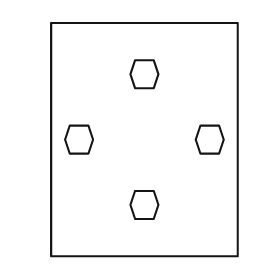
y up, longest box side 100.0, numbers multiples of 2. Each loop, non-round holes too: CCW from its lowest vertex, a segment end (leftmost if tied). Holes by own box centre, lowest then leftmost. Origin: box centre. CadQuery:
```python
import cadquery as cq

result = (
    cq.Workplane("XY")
    .moveTo(-40.0, -50.0)
    .lineTo(40.0, -50.0)
    .lineTo(40.0, 50.0)
    .lineTo(-40.0, 50.0)
    .close()
    .moveTo(-4.0, -34.0)
    .lineTo(4.0, -34.0)
    .lineTo(6.0, -28.0)
    .lineTo(4.0, -22.0)
    .lineTo(-4.0, -22.0)
    .lineTo(-6.0, -28.0)
    .close()
    .moveTo(-32.0, -6.0)
    .lineTo(-24.0, -6.0)
    .lineTo(-22.0, 0.0)
    .lineTo(-24.0, 6.0)
    .lineTo(-32.0, 6.0)
    .lineTo(-34.0, 0.0)
    .close()
    .moveTo(24.0, -6.0)
    .lineTo(32.0, -6.0)
    .lineTo(34.0, 0.0)
    .lineTo(32.0, 6.0)
    .lineTo(24.0, 6.0)
    .lineTo(22.0, 0.0)
    .close()
    .moveTo(-4.0, 22.0)
    .lineTo(4.0, 22.0)
    .lineTo(6.0, 28.0)
    .lineTo(4.0, 34.0)
    .lineTo(-4.0, 34.0)
    .lineTo(-6.0, 28.0)
    .close()
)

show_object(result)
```